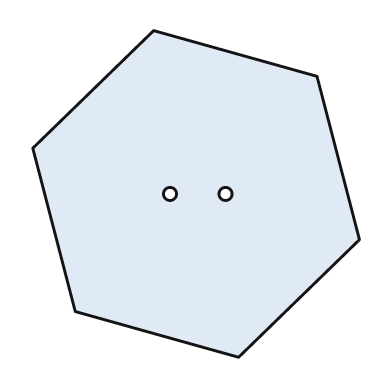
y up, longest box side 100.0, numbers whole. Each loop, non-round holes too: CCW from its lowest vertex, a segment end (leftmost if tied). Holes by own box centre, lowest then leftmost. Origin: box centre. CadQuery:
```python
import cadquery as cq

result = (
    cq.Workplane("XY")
    .moveTo(13.0, -50.0)
    .lineTo(50.0, -14.0)
    .lineTo(37.0, 36.0)
    .lineTo(-13.0, 50.0)
    .lineTo(-50.0, 14.0)
    .lineTo(-37.0, -36.0)
    .close()
    .moveTo(-8.0, 0.0)
    .circle(2.0)
    .moveTo(9.0, 0.0)
    .circle(2.0)
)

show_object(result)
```